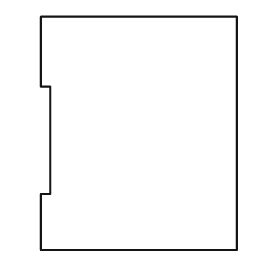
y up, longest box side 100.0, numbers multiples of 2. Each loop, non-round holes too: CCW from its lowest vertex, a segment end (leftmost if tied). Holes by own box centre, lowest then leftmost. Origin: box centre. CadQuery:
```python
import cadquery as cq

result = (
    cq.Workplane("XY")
    .moveTo(-42.0, -50.0)
    .lineTo(42.0, -50.0)
    .lineTo(42.0, 50.0)
    .lineTo(-42.0, 50.0)
    .lineTo(-42.0, 20.0)
    .lineTo(-38.0, 20.0)
    .lineTo(-38.0, -26.0)
    .lineTo(-42.0, -26.0)
    .close()
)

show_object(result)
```